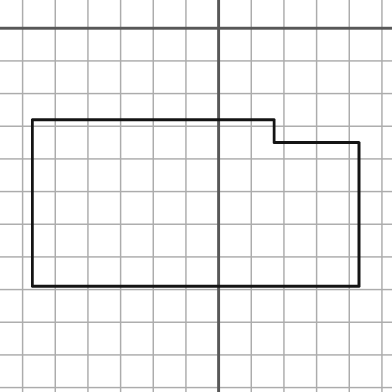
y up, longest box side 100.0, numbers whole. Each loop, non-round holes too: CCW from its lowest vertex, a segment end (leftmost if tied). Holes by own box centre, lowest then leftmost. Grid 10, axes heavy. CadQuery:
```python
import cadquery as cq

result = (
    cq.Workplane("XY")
    .moveTo(-57.0, -79.0)
    .lineTo(43.0, -79.0)
    .lineTo(43.0, -35.0)
    .lineTo(17.0, -35.0)
    .lineTo(17.0, -28.0)
    .lineTo(-57.0, -28.0)
    .close()
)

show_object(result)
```